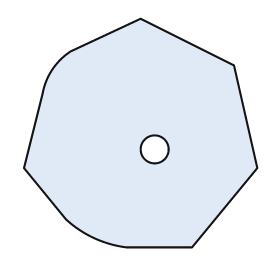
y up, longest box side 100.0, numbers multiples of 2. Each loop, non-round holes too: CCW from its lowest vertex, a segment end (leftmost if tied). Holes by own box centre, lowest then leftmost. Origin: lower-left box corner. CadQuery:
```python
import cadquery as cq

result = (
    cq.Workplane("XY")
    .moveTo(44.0, 0.0)
    .lineTo(72.0, 0.0)
    .lineTo(100.0, 34.0)
    .lineTo(90.0, 78.0)
    .lineTo(50.0, 98.0)
    .lineTo(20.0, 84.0)
    .threePointArc((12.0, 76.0), (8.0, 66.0))
    .lineTo(0.0, 34.0)
    .lineTo(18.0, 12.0)
    .threePointArc((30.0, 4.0), (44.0, 0.0))
    .close()
    .moveTo(56.0, 42.0)
    .circle(6.0)
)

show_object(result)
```